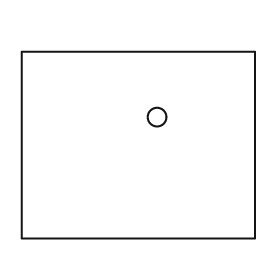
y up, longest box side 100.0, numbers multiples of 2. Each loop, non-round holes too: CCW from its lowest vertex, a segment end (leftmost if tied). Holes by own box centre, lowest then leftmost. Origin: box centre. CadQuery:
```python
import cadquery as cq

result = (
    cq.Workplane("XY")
    .moveTo(-50.0, -40.0)
    .lineTo(50.0, -40.0)
    .lineTo(50.0, 40.0)
    .lineTo(-50.0, 40.0)
    .close()
    .moveTo(8.0, 12.0)
    .circle(4.0)
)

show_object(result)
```